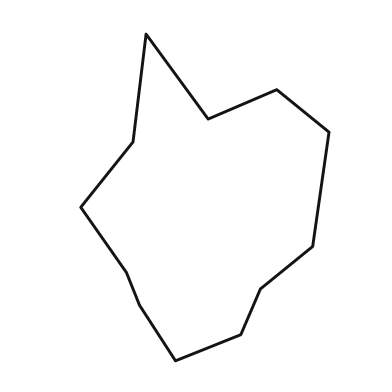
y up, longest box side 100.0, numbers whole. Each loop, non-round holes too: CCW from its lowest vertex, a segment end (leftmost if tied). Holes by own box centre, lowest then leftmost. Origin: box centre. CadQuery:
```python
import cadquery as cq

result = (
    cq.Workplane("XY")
    .moveTo(-9.0, -50.0)
    .lineTo(11.0, -42.0)
    .lineTo(17.0, -28.0)
    .lineTo(33.0, -15.0)
    .lineTo(38.0, 20.0)
    .lineTo(22.0, 33.0)
    .lineTo(1.0, 24.0)
    .lineTo(-18.0, 50.0)
    .lineTo(-22.0, 17.0)
    .lineTo(-38.0, -3.0)
    .lineTo(-24.0, -23.0)
    .lineTo(-20.0, -33.0)
    .close()
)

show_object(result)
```